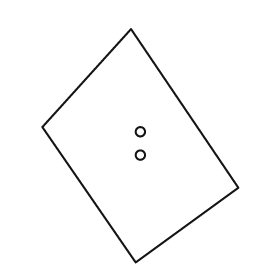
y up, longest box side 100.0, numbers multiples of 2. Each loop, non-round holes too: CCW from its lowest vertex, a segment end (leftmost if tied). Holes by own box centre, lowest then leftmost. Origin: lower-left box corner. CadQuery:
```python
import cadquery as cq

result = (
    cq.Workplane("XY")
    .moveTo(40.0, 0.0)
    .lineTo(84.0, 32.0)
    .lineTo(38.0, 100.0)
    .lineTo(0.0, 58.0)
    .close()
    .moveTo(42.0, 46.0)
    .circle(2.0)
    .moveTo(42.0, 56.0)
    .circle(2.0)
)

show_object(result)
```